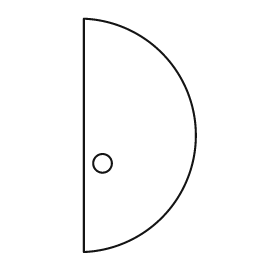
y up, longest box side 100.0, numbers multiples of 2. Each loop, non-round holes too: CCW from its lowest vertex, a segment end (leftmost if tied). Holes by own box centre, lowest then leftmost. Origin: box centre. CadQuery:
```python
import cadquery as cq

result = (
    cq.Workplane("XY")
    .moveTo(-24.0, -50.0)
    .threePointArc((24.0, 0.0), (-24.0, 50.0))
    .close()
    .moveTo(-16.0, -12.0)
    .circle(4.0)
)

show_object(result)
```